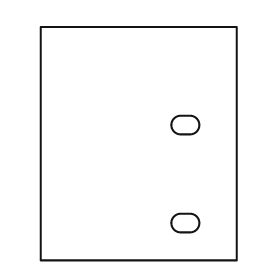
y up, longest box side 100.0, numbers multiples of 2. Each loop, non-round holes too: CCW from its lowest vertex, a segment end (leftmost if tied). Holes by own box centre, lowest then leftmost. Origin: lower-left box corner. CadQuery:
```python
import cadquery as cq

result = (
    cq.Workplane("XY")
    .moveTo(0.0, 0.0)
    .lineTo(84.0, 0.0)
    .lineTo(84.0, 100.0)
    .lineTo(0.0, 100.0)
    .close()
    .moveTo(60.0, 12.0)
    .lineTo(64.0, 12.0)
    .threePointArc((68.0, 16.0), (64.0, 20.0))
    .lineTo(60.0, 20.0)
    .threePointArc((56.0, 16.0), (60.0, 12.0))
    .close()
    .moveTo(60.0, 54.0)
    .lineTo(64.0, 54.0)
    .threePointArc((68.0, 58.0), (64.0, 62.0))
    .lineTo(60.0, 62.0)
    .threePointArc((56.0, 58.0), (60.0, 54.0))
    .close()
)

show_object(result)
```